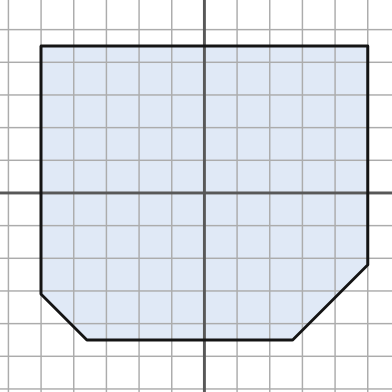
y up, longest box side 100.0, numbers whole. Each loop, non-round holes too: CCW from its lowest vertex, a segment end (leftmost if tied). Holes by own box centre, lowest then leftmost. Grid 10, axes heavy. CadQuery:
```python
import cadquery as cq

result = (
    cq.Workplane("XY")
    .moveTo(-36.0, -45.0)
    .lineTo(27.0, -45.0)
    .lineTo(50.0, -22.0)
    .lineTo(50.0, 45.0)
    .lineTo(-50.0, 45.0)
    .lineTo(-50.0, -31.0)
    .close()
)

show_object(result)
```